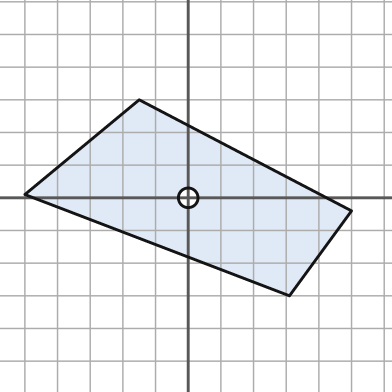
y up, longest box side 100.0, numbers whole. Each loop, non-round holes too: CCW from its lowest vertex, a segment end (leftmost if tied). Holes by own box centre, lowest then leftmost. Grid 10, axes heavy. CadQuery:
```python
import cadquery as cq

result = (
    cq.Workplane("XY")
    .moveTo(31.0, -30.0)
    .lineTo(50.0, -4.0)
    .lineTo(-15.0, 30.0)
    .lineTo(-50.0, 1.0)
    .close()
    .moveTo(0.0, 0.0)
    .circle(3.0)
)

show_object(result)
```